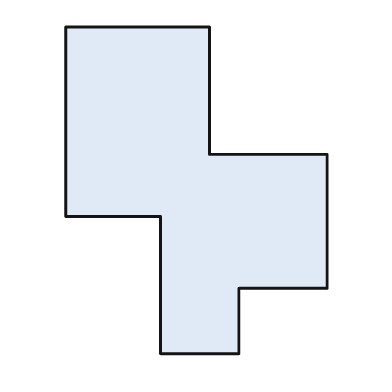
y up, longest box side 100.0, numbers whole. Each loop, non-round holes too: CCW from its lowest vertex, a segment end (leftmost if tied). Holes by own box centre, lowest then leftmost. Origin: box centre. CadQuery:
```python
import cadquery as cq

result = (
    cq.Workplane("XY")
    .moveTo(-11.0, -50.0)
    .lineTo(13.0, -50.0)
    .lineTo(13.0, -30.0)
    .lineTo(40.0, -30.0)
    .lineTo(40.0, 11.0)
    .lineTo(4.0, 11.0)
    .lineTo(4.0, 50.0)
    .lineTo(-40.0, 50.0)
    .lineTo(-40.0, -8.0)
    .lineTo(-11.0, -8.0)
    .close()
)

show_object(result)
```